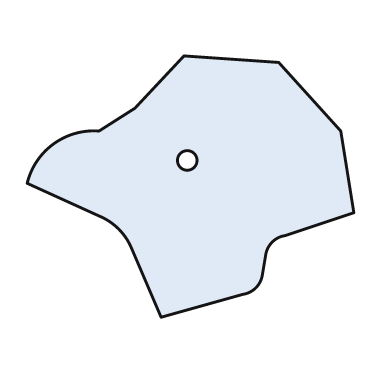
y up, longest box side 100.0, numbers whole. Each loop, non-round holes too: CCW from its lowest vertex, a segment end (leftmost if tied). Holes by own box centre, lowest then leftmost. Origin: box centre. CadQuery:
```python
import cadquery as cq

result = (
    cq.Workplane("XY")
    .moveTo(-9.0, -40.0)
    .lineTo(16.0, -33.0)
    .threePointArc((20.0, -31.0), (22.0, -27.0))
    .lineTo(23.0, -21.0)
    .threePointArc((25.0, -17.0), (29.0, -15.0))
    .lineTo(50.0, -8.0)
    .lineTo(46.0, 17.0)
    .lineTo(27.0, 38.0)
    .lineTo(-2.0, 40.0)
    .lineTo(-17.0, 24.0)
    .lineTo(-28.0, 17.0)
    .threePointArc((-42.0, 13.0), (-50.0, 1.0))
    .lineTo(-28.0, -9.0)
    .threePointArc((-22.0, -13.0), (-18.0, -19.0))
    .close()
    .moveTo(-1.0, 8.0)
    .circle(3.0)
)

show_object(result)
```